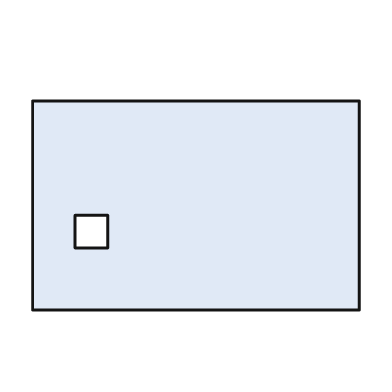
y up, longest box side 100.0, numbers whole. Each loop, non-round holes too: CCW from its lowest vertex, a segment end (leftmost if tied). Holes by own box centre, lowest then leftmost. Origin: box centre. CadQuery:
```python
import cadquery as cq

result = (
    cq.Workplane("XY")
    .moveTo(-50.0, -32.0)
    .lineTo(50.0, -32.0)
    .lineTo(50.0, 32.0)
    .lineTo(-50.0, 32.0)
    .close()
    .moveTo(-37.0, -13.0)
    .lineTo(-27.0, -13.0)
    .lineTo(-27.0, -3.0)
    .lineTo(-37.0, -3.0)
    .close()
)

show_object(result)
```